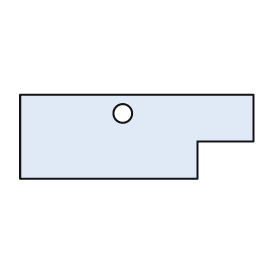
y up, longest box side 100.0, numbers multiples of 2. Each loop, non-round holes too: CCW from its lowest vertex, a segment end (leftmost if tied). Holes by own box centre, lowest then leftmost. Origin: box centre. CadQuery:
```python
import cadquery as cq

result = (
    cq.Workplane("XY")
    .moveTo(-50.0, -18.0)
    .lineTo(26.0, -18.0)
    .lineTo(26.0, -2.0)
    .lineTo(50.0, -2.0)
    .lineTo(50.0, 18.0)
    .lineTo(-50.0, 18.0)
    .close()
    .moveTo(-6.0, 10.0)
    .circle(4.0)
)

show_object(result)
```